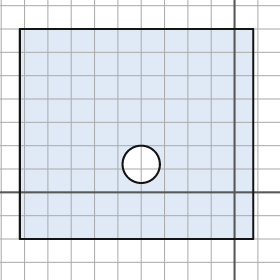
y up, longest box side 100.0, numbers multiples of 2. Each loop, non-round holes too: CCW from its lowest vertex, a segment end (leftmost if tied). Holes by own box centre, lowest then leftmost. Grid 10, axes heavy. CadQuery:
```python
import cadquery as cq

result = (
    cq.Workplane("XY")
    .moveTo(-92.0, -20.0)
    .lineTo(8.0, -20.0)
    .lineTo(8.0, 70.0)
    .lineTo(-92.0, 70.0)
    .close()
    .moveTo(-40.0, 12.0)
    .circle(8.0)
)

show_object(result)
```